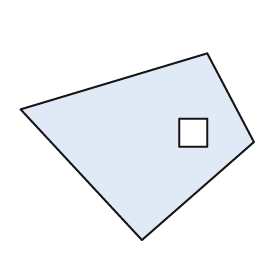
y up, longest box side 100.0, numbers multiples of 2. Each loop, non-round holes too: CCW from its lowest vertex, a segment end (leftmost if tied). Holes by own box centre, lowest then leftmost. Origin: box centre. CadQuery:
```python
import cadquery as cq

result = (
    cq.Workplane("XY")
    .moveTo(2.0, -40.0)
    .lineTo(50.0, 2.0)
    .lineTo(30.0, 40.0)
    .lineTo(-50.0, 16.0)
    .close()
    .moveTo(18.0, 0.0)
    .lineTo(30.0, 0.0)
    .lineTo(30.0, 12.0)
    .lineTo(18.0, 12.0)
    .close()
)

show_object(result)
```